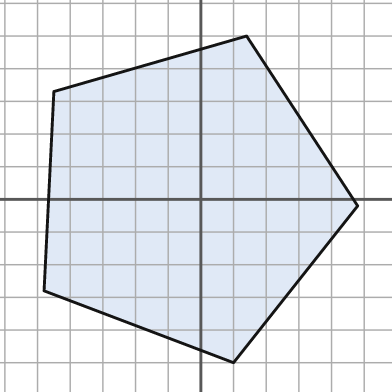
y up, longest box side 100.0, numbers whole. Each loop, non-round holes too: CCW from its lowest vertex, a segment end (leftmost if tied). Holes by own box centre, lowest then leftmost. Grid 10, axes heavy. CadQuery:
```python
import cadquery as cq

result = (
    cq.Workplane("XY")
    .moveTo(10.0, -50.0)
    .lineTo(48.0, -2.0)
    .lineTo(14.0, 50.0)
    .lineTo(-45.0, 33.0)
    .lineTo(-48.0, -28.0)
    .close()
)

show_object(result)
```